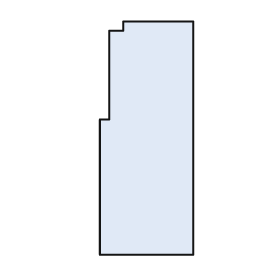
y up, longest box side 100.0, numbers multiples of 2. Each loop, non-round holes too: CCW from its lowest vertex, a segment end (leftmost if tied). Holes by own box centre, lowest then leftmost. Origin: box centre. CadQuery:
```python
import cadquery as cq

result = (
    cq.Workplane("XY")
    .moveTo(-20.0, -50.0)
    .lineTo(20.0, -50.0)
    .lineTo(20.0, 50.0)
    .lineTo(-10.0, 50.0)
    .lineTo(-10.0, 46.0)
    .lineTo(-16.0, 46.0)
    .lineTo(-16.0, 8.0)
    .lineTo(-20.0, 8.0)
    .close()
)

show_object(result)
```